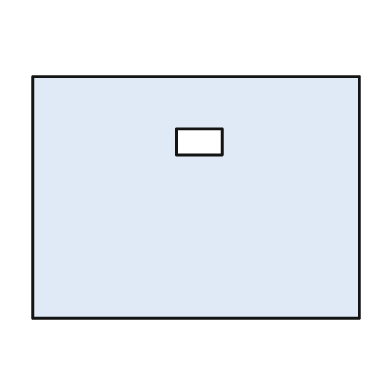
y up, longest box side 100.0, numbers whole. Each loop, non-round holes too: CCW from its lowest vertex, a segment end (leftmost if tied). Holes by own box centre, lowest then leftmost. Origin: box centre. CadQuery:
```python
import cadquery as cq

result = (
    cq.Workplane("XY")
    .moveTo(-50.0, -37.0)
    .lineTo(50.0, -37.0)
    .lineTo(50.0, 37.0)
    .lineTo(-50.0, 37.0)
    .close()
    .moveTo(-6.0, 13.0)
    .lineTo(8.0, 13.0)
    .lineTo(8.0, 21.0)
    .lineTo(-6.0, 21.0)
    .close()
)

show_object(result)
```